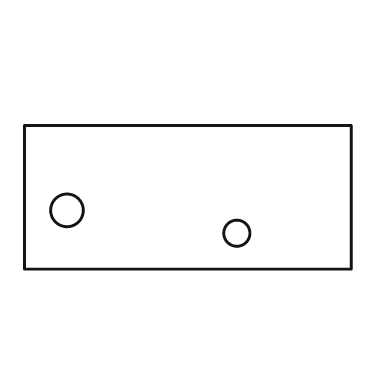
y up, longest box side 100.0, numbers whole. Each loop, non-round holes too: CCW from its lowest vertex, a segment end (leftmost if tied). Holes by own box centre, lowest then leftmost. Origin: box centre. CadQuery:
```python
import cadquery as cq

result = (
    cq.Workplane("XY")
    .moveTo(-50.0, -22.0)
    .lineTo(50.0, -22.0)
    .lineTo(50.0, 22.0)
    .lineTo(-50.0, 22.0)
    .close()
    .moveTo(15.0, -11.0)
    .circle(4.0)
    .moveTo(-37.0, -4.0)
    .circle(5.0)
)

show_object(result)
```